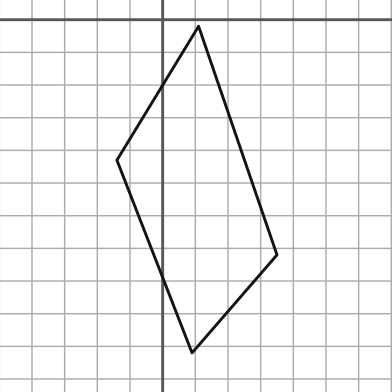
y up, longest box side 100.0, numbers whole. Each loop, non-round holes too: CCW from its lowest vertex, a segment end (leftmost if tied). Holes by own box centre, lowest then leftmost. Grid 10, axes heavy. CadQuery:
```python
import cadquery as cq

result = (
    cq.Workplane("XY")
    .moveTo(9.0, -102.0)
    .lineTo(35.0, -72.0)
    .lineTo(11.0, -2.0)
    .lineTo(-14.0, -43.0)
    .close()
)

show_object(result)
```